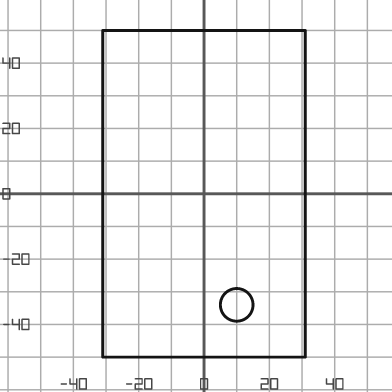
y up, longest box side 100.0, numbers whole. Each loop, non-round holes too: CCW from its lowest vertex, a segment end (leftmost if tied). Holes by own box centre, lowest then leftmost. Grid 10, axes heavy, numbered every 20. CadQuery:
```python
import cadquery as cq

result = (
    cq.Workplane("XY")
    .moveTo(-31.0, -50.0)
    .lineTo(31.0, -50.0)
    .lineTo(31.0, 50.0)
    .lineTo(-31.0, 50.0)
    .close()
    .moveTo(10.0, -34.0)
    .circle(5.0)
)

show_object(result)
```